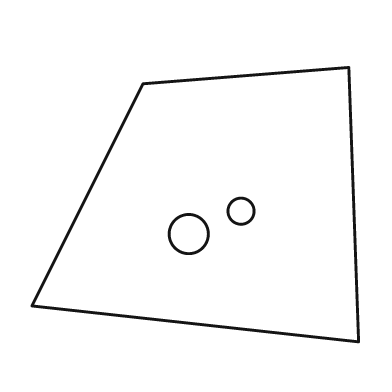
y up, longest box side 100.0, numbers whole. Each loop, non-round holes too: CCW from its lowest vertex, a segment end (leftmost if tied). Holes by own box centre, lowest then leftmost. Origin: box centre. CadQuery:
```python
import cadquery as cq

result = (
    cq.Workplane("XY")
    .moveTo(50.0, -42.0)
    .lineTo(47.0, 42.0)
    .lineTo(-16.0, 37.0)
    .lineTo(-50.0, -31.0)
    .close()
    .moveTo(-2.0, -9.0)
    .circle(6.0)
    .moveTo(14.0, -2.0)
    .circle(4.0)
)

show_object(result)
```